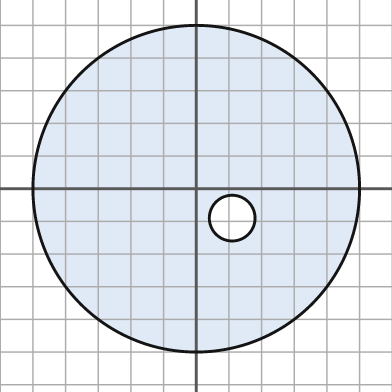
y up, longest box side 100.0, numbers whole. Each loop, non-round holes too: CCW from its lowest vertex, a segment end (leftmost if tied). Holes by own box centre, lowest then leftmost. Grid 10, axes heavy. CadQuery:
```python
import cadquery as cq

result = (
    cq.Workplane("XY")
    .moveTo(0.0, 0.0)
    .circle(50.0)
    .moveTo(11.0, -9.0)
    .circle(7.0)
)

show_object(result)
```